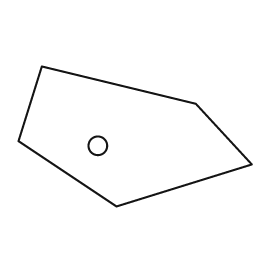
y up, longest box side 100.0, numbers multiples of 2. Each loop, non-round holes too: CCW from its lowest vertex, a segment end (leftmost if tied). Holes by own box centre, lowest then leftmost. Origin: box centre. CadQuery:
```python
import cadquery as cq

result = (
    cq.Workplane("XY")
    .moveTo(-8.0, -30.0)
    .lineTo(50.0, -12.0)
    .lineTo(26.0, 14.0)
    .lineTo(-40.0, 30.0)
    .lineTo(-50.0, -2.0)
    .close()
    .moveTo(-16.0, -4.0)
    .circle(4.0)
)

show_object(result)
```